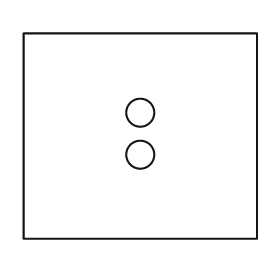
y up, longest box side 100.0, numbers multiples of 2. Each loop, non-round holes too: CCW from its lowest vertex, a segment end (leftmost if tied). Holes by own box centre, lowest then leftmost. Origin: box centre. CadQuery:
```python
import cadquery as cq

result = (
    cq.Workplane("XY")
    .moveTo(-50.0, -44.0)
    .lineTo(50.0, -44.0)
    .lineTo(50.0, 44.0)
    .lineTo(-50.0, 44.0)
    .close()
    .moveTo(0.0, -8.0)
    .circle(6.0)
    .moveTo(0.0, 10.0)
    .circle(6.0)
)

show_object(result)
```